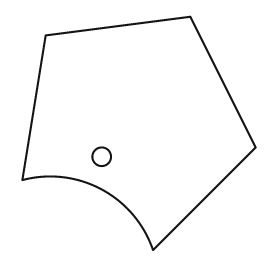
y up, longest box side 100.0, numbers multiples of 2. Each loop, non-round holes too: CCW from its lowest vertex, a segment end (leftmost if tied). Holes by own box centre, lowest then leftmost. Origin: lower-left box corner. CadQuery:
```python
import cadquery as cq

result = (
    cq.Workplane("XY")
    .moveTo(56.0, 0.0)
    .lineTo(100.0, 44.0)
    .lineTo(72.0, 100.0)
    .lineTo(10.0, 92.0)
    .lineTo(0.0, 30.0)
    .threePointArc((34.0, 26.0), (56.0, 0.0))
    .close()
    .moveTo(34.0, 40.0)
    .circle(4.0)
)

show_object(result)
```